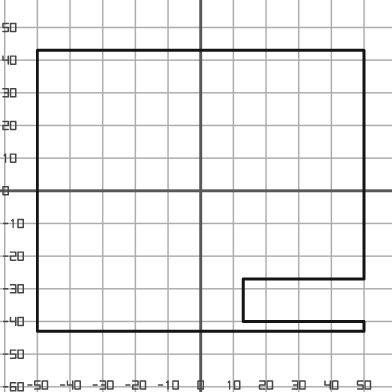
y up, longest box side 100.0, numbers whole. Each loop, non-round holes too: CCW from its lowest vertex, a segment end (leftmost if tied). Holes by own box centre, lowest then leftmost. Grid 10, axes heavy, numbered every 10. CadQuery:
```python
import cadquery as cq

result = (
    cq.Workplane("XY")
    .moveTo(-50.0, -43.0)
    .lineTo(50.0, -43.0)
    .lineTo(50.0, -40.0)
    .lineTo(13.0, -40.0)
    .lineTo(13.0, -27.0)
    .lineTo(50.0, -27.0)
    .lineTo(50.0, 43.0)
    .lineTo(-50.0, 43.0)
    .close()
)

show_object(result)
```